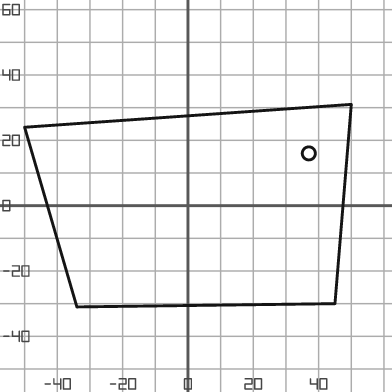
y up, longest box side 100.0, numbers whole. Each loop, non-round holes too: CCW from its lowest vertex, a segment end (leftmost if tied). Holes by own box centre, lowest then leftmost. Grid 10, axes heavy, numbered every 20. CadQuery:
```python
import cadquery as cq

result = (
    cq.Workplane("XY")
    .moveTo(-34.0, -31.0)
    .lineTo(45.0, -30.0)
    .lineTo(50.0, 31.0)
    .lineTo(-50.0, 24.0)
    .close()
    .moveTo(37.0, 16.0)
    .circle(2.0)
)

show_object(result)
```